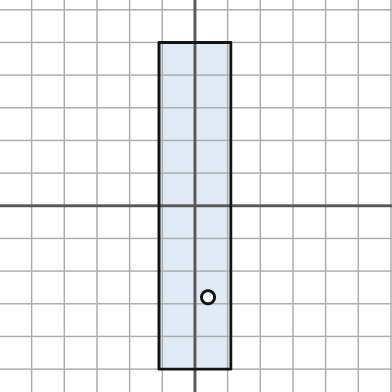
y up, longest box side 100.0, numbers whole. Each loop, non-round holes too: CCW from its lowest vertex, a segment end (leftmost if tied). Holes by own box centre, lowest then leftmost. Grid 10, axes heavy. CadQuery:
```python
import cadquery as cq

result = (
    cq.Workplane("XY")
    .moveTo(-11.0, -50.0)
    .lineTo(11.0, -50.0)
    .lineTo(11.0, 50.0)
    .lineTo(-11.0, 50.0)
    .close()
    .moveTo(4.0, -28.0)
    .circle(2.0)
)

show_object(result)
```